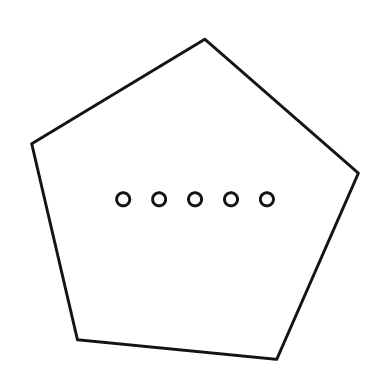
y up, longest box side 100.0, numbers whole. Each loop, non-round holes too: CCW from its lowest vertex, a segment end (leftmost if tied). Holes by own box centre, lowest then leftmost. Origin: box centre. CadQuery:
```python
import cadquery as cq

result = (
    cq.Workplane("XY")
    .moveTo(25.0, -49.0)
    .lineTo(50.0, 8.0)
    .lineTo(3.0, 49.0)
    .lineTo(-50.0, 17.0)
    .lineTo(-36.0, -43.0)
    .close()
    .moveTo(-22.0, 0.0)
    .circle(2.0)
    .moveTo(-11.0, 0.0)
    .circle(2.0)
    .moveTo(0.0, 0.0)
    .circle(2.0)
    .moveTo(11.0, 0.0)
    .circle(2.0)
    .moveTo(22.0, 0.0)
    .circle(2.0)
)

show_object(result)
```